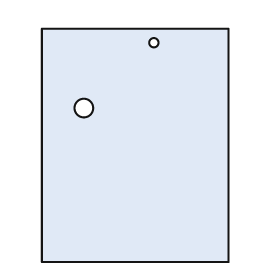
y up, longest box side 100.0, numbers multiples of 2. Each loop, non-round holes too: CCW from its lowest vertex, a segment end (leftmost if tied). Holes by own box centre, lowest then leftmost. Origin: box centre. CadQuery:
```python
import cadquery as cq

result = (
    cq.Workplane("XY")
    .moveTo(-40.0, -50.0)
    .lineTo(40.0, -50.0)
    .lineTo(40.0, 50.0)
    .lineTo(-40.0, 50.0)
    .close()
    .moveTo(-22.0, 16.0)
    .circle(4.0)
    .moveTo(8.0, 44.0)
    .circle(2.0)
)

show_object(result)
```